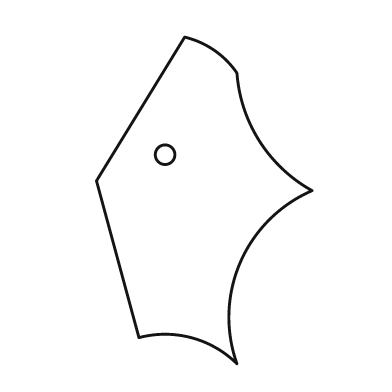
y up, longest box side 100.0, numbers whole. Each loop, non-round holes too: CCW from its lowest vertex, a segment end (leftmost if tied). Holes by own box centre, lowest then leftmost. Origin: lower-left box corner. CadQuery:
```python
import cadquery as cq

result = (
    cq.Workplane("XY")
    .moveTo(43.0, 0.0)
    .threePointArc((44.0, 31.0), (66.0, 53.0))
    .threePointArc((50.0, 68.0), (43.0, 89.0))
    .threePointArc((36.0, 96.0), (27.0, 100.0))
    .lineTo(0.0, 56.0)
    .lineTo(13.0, 8.0)
    .threePointArc((29.0, 8.0), (43.0, 0.0))
    .close()
    .moveTo(21.0, 64.0)
    .circle(3.0)
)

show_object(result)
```